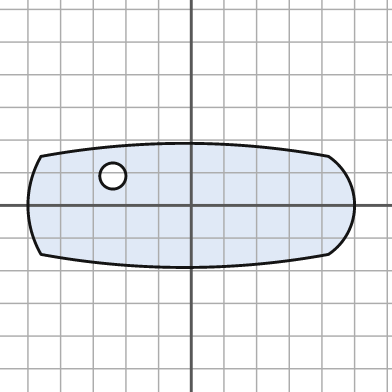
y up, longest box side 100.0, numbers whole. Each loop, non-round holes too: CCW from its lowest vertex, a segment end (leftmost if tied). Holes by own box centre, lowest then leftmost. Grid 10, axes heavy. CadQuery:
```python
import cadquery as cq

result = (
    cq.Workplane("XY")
    .moveTo(-46.0, -15.0)
    .threePointArc((-2.0, -19.0), (42.0, -15.0))
    .threePointArc((50.0, 0.0), (42.0, 15.0))
    .threePointArc((-2.0, 19.0), (-46.0, 15.0))
    .threePointArc((-50.0, 0.0), (-46.0, -15.0))
    .close()
    .moveTo(-24.0, 9.0)
    .circle(4.0)
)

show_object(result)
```